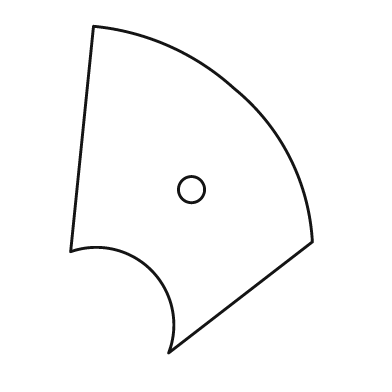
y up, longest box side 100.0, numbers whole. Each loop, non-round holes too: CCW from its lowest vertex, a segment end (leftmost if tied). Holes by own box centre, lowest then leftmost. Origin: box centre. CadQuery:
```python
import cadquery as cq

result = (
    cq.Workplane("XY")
    .moveTo(-7.0, -50.0)
    .lineTo(37.0, -16.0)
    .threePointArc((30.0, 10.0), (13.0, 31.0))
    .threePointArc((-7.0, 44.0), (-30.0, 50.0))
    .lineTo(-37.0, -19.0)
    .threePointArc((-12.0, -25.0), (-7.0, -50.0))
    .close()
    .moveTo(0.0, 0.0)
    .circle(4.0)
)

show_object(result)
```